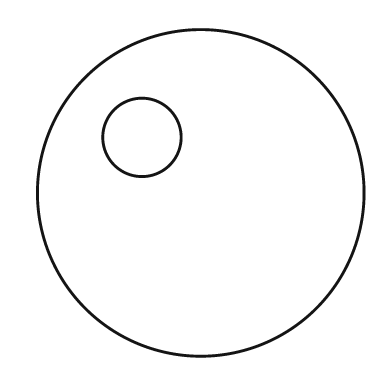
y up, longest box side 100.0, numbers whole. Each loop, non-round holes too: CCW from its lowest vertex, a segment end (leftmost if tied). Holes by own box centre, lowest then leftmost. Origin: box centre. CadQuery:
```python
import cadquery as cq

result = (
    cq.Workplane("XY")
    .moveTo(0.0, 0.0)
    .circle(50.0)
    .moveTo(-18.0, 17.0)
    .circle(12.0)
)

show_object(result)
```